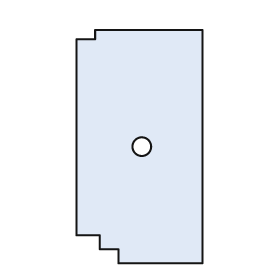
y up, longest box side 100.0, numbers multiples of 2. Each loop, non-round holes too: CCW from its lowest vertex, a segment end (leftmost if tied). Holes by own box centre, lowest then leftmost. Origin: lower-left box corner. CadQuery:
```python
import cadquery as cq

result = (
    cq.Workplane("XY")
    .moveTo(18.0, 0.0)
    .lineTo(54.0, 0.0)
    .lineTo(54.0, 100.0)
    .lineTo(8.0, 100.0)
    .lineTo(8.0, 96.0)
    .lineTo(0.0, 96.0)
    .lineTo(0.0, 12.0)
    .lineTo(10.0, 12.0)
    .lineTo(10.0, 6.0)
    .lineTo(18.0, 6.0)
    .close()
    .moveTo(28.0, 50.0)
    .circle(4.0)
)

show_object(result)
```